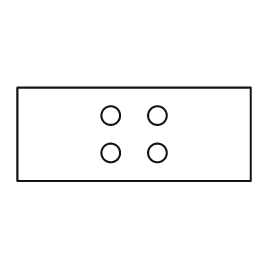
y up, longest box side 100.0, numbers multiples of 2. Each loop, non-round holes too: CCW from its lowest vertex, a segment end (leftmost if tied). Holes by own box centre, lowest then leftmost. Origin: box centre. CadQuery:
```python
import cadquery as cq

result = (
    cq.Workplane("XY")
    .moveTo(-50.0, -20.0)
    .lineTo(50.0, -20.0)
    .lineTo(50.0, 20.0)
    .lineTo(-50.0, 20.0)
    .close()
    .moveTo(-10.0, -8.0)
    .circle(4.0)
    .moveTo(10.0, -8.0)
    .circle(4.0)
    .moveTo(-10.0, 8.0)
    .circle(4.0)
    .moveTo(10.0, 8.0)
    .circle(4.0)
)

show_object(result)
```